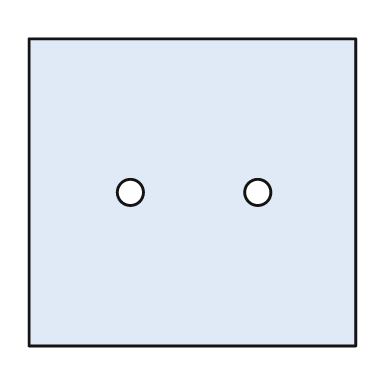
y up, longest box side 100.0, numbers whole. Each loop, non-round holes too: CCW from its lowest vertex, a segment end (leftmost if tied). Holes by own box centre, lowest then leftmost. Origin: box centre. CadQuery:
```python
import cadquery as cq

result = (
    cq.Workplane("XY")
    .moveTo(-50.0, -47.0)
    .lineTo(50.0, -47.0)
    .lineTo(50.0, 47.0)
    .lineTo(-50.0, 47.0)
    .close()
    .moveTo(-19.0, 0.0)
    .circle(4.0)
    .moveTo(20.0, 0.0)
    .circle(4.0)
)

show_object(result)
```